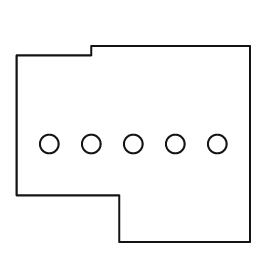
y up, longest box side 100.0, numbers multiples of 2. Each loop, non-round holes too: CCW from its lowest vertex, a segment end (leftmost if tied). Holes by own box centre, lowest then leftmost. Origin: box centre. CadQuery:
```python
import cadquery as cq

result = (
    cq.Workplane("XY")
    .moveTo(-6.0, -42.0)
    .lineTo(50.0, -42.0)
    .lineTo(50.0, 42.0)
    .lineTo(-18.0, 42.0)
    .lineTo(-18.0, 38.0)
    .lineTo(-50.0, 38.0)
    .lineTo(-50.0, -22.0)
    .lineTo(-6.0, -22.0)
    .close()
    .moveTo(-36.0, 0.0)
    .circle(4.0)
    .moveTo(-18.0, 0.0)
    .circle(4.0)
    .moveTo(0.0, 0.0)
    .circle(4.0)
    .moveTo(18.0, 0.0)
    .circle(4.0)
    .moveTo(36.0, 0.0)
    .circle(4.0)
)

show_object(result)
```